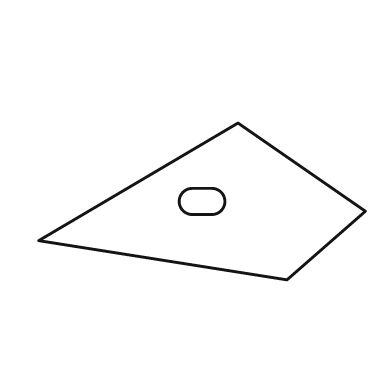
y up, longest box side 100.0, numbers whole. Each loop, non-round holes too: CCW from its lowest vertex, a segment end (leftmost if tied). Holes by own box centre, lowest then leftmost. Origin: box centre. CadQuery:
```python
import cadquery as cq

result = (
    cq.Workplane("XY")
    .moveTo(26.0, -24.0)
    .lineTo(50.0, -3.0)
    .lineTo(11.0, 24.0)
    .lineTo(-50.0, -12.0)
    .close()
    .moveTo(-3.0, -4.0)
    .lineTo(3.0, -4.0)
    .threePointArc((7.0, 0.0), (3.0, 4.0))
    .lineTo(-3.0, 4.0)
    .threePointArc((-7.0, 0.0), (-3.0, -4.0))
    .close()
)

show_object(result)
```